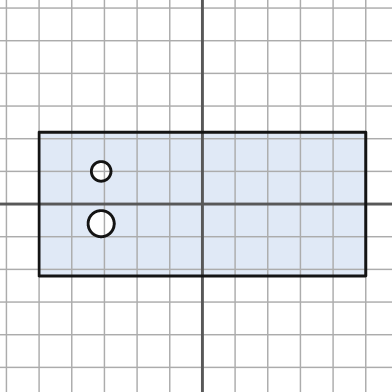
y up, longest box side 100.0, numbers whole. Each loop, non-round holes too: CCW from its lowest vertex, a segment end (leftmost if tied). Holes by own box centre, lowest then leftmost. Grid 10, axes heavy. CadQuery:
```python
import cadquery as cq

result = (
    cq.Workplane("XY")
    .moveTo(-50.0, -22.0)
    .lineTo(50.0, -22.0)
    .lineTo(50.0, 22.0)
    .lineTo(-50.0, 22.0)
    .close()
    .moveTo(-31.0, -6.0)
    .circle(4.0)
    .moveTo(-31.0, 10.0)
    .circle(3.0)
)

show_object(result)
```